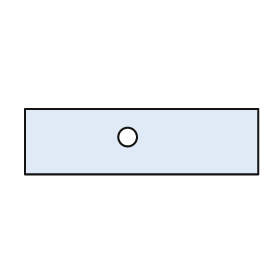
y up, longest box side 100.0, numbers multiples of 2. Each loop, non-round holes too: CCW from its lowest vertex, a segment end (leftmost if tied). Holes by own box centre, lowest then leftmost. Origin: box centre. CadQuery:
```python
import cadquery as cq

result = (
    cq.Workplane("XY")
    .moveTo(-50.0, -14.0)
    .lineTo(50.0, -14.0)
    .lineTo(50.0, 14.0)
    .lineTo(-50.0, 14.0)
    .close()
    .moveTo(-6.0, 2.0)
    .circle(4.0)
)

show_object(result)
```